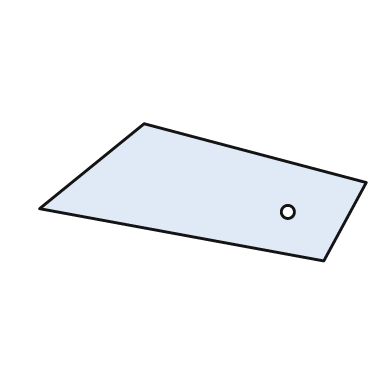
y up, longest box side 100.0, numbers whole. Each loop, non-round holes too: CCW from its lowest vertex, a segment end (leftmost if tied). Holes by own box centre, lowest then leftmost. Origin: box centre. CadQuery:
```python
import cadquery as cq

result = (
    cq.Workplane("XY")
    .moveTo(37.0, -21.0)
    .lineTo(50.0, 3.0)
    .lineTo(-18.0, 21.0)
    .lineTo(-50.0, -5.0)
    .close()
    .moveTo(26.0, -6.0)
    .circle(2.0)
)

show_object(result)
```